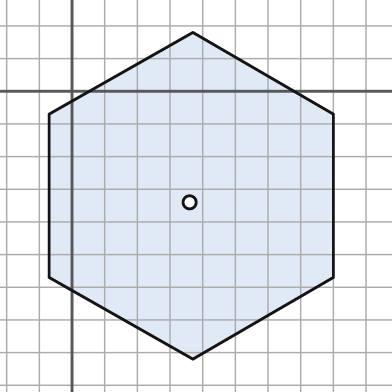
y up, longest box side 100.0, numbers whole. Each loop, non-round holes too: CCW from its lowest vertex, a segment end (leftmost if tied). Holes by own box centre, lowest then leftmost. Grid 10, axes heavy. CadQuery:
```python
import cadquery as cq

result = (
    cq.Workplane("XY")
    .moveTo(37.0, -82.0)
    .lineTo(80.0, -57.0)
    .lineTo(80.0, -7.0)
    .lineTo(37.0, 18.0)
    .lineTo(-7.0, -7.0)
    .lineTo(-7.0, -57.0)
    .close()
    .moveTo(36.0, -34.0)
    .circle(2.0)
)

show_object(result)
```